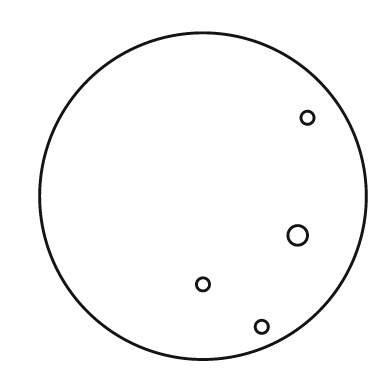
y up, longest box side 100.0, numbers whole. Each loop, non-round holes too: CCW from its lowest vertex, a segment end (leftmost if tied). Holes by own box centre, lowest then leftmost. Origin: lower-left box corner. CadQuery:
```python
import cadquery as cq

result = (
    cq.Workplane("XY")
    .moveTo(50.0, 50.0)
    .circle(50.0)
    .moveTo(68.0, 10.0)
    .circle(2.0)
    .moveTo(50.0, 23.0)
    .circle(2.0)
    .moveTo(79.0, 38.0)
    .circle(3.0)
    .moveTo(82.0, 74.0)
    .circle(2.0)
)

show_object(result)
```